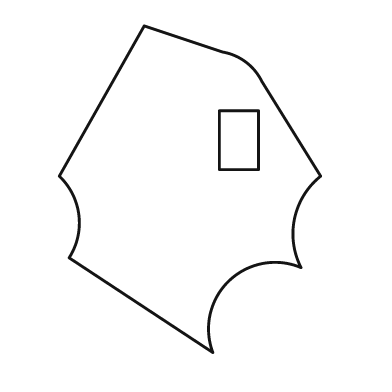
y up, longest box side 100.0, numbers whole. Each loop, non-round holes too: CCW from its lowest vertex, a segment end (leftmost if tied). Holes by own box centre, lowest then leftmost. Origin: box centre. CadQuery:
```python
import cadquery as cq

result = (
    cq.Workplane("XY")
    .moveTo(7.0, -50.0)
    .threePointArc((12.0, -28.0), (34.0, -24.0))
    .threePointArc((32.0, -9.0), (40.0, 4.0))
    .lineTo(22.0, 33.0)
    .threePointArc((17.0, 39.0), (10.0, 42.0))
    .lineTo(-14.0, 50.0)
    .lineTo(-40.0, 4.0)
    .threePointArc((-34.0, -8.0), (-37.0, -21.0))
    .close()
    .moveTo(9.0, 6.0)
    .lineTo(21.0, 6.0)
    .lineTo(21.0, 24.0)
    .lineTo(9.0, 24.0)
    .close()
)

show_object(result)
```